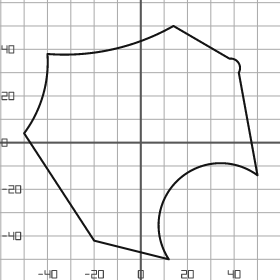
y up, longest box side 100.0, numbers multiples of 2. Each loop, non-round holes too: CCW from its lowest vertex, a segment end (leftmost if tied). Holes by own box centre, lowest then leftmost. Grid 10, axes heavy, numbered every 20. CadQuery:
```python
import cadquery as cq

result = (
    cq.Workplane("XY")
    .moveTo(12.0, -50.0)
    .threePointArc((16.0, -16.0), (50.0, -14.0))
    .lineTo(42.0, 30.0)
    .threePointArc((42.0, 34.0), (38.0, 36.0))
    .lineTo(14.0, 50.0)
    .threePointArc((-12.0, 40.0), (-40.0, 38.0))
    .threePointArc((-42.0, 20.0), (-50.0, 4.0))
    .lineTo(-20.0, -42.0)
    .close()
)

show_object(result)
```